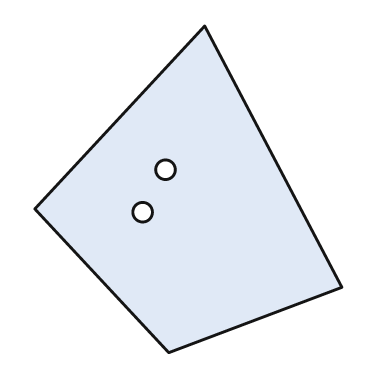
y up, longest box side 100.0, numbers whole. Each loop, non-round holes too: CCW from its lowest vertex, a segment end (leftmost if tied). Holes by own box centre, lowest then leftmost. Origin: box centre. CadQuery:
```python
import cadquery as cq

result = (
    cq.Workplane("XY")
    .moveTo(-6.0, -50.0)
    .lineTo(47.0, -30.0)
    .lineTo(5.0, 50.0)
    .lineTo(-47.0, -6.0)
    .close()
    .moveTo(-14.0, -7.0)
    .circle(3.0)
    .moveTo(-7.0, 6.0)
    .circle(3.0)
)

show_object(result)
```